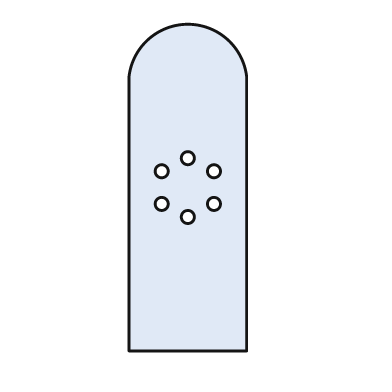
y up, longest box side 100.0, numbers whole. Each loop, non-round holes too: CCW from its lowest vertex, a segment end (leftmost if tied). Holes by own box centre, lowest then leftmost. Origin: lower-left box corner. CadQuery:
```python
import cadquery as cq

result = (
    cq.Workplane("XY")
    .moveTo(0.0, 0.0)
    .lineTo(36.0, 0.0)
    .lineTo(36.0, 84.0)
    .threePointArc((18.0, 100.0), (0.0, 84.0))
    .close()
    .moveTo(18.0, 41.0)
    .circle(2.0)
    .moveTo(10.0, 45.0)
    .circle(2.0)
    .moveTo(26.0, 45.0)
    .circle(2.0)
    .moveTo(10.0, 55.0)
    .circle(2.0)
    .moveTo(26.0, 55.0)
    .circle(2.0)
    .moveTo(18.0, 59.0)
    .circle(2.0)
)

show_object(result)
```